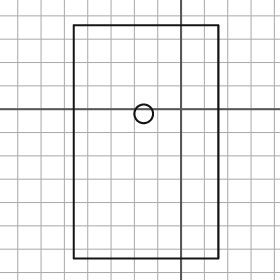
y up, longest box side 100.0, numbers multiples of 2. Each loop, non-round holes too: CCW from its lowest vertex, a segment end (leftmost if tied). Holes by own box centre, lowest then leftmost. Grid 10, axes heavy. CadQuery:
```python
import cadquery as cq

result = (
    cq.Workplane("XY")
    .moveTo(-46.0, -64.0)
    .lineTo(16.0, -64.0)
    .lineTo(16.0, 36.0)
    .lineTo(-46.0, 36.0)
    .close()
    .moveTo(-16.0, -2.0)
    .circle(4.0)
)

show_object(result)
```